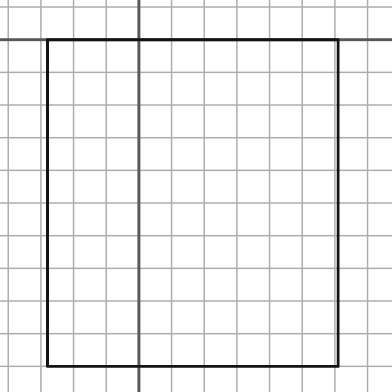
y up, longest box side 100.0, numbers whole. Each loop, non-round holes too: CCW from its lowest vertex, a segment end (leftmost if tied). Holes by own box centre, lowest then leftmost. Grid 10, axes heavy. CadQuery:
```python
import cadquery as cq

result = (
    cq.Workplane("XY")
    .moveTo(-28.0, -100.0)
    .lineTo(61.0, -100.0)
    .lineTo(61.0, 0.0)
    .lineTo(-28.0, 0.0)
    .close()
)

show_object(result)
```